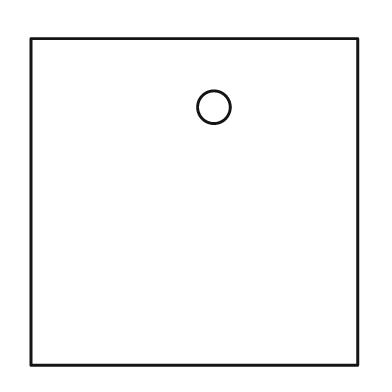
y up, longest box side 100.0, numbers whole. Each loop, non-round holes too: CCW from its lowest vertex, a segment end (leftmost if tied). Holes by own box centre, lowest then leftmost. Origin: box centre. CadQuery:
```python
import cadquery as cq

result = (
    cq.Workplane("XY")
    .moveTo(-50.0, -50.0)
    .lineTo(50.0, -50.0)
    .lineTo(50.0, 50.0)
    .lineTo(-50.0, 50.0)
    .close()
    .moveTo(6.0, 29.0)
    .circle(5.0)
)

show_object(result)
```